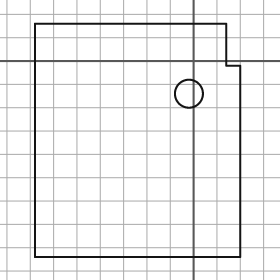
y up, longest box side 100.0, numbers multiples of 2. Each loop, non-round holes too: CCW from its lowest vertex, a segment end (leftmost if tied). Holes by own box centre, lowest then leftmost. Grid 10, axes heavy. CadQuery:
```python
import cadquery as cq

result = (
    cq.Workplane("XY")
    .moveTo(-68.0, -84.0)
    .lineTo(20.0, -84.0)
    .lineTo(20.0, -2.0)
    .lineTo(14.0, -2.0)
    .lineTo(14.0, 16.0)
    .lineTo(-68.0, 16.0)
    .close()
    .moveTo(-2.0, -14.0)
    .circle(6.0)
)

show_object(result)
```